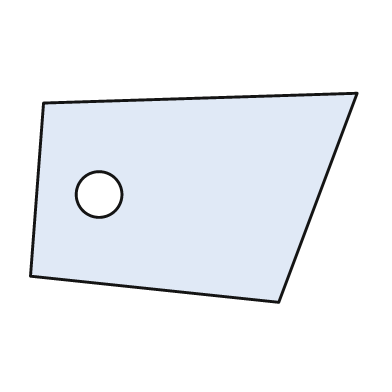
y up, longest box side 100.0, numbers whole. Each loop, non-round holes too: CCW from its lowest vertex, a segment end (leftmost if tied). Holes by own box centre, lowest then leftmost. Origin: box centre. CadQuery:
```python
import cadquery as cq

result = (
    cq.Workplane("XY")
    .moveTo(26.0, -32.0)
    .lineTo(50.0, 32.0)
    .lineTo(-46.0, 29.0)
    .lineTo(-50.0, -24.0)
    .close()
    .moveTo(-29.0, 1.0)
    .circle(7.0)
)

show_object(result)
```